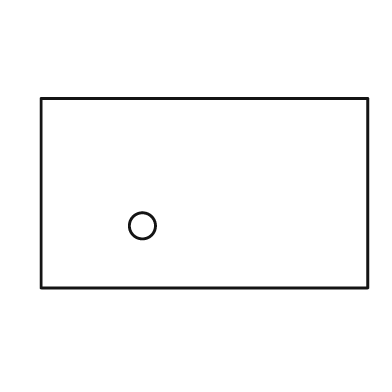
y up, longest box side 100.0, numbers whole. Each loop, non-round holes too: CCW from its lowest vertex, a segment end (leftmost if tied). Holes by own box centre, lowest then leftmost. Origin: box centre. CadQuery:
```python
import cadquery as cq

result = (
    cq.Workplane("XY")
    .moveTo(-50.0, -29.0)
    .lineTo(50.0, -29.0)
    .lineTo(50.0, 29.0)
    .lineTo(-50.0, 29.0)
    .close()
    .moveTo(-19.0, -10.0)
    .circle(4.0)
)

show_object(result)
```